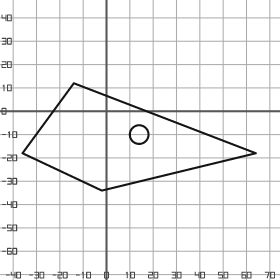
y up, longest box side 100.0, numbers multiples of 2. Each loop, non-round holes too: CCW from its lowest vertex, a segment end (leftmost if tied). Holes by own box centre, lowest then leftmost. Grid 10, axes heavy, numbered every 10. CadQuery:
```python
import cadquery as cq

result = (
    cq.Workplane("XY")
    .moveTo(-2.0, -34.0)
    .lineTo(64.0, -18.0)
    .lineTo(-14.0, 12.0)
    .lineTo(-36.0, -18.0)
    .close()
    .moveTo(14.0, -10.0)
    .circle(4.0)
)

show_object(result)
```